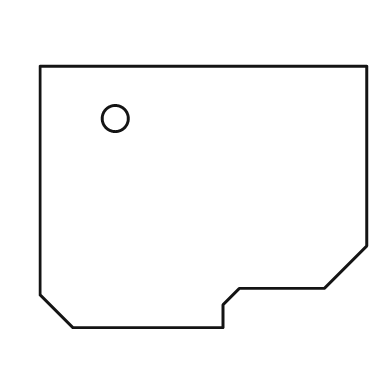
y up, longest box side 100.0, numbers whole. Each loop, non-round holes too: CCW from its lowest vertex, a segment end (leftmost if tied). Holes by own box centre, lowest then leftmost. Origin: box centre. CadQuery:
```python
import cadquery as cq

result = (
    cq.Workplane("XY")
    .moveTo(-40.0, -40.0)
    .lineTo(6.0, -40.0)
    .lineTo(6.0, -33.0)
    .lineTo(11.0, -28.0)
    .lineTo(37.0, -28.0)
    .lineTo(50.0, -15.0)
    .lineTo(50.0, 40.0)
    .lineTo(-50.0, 40.0)
    .lineTo(-50.0, -30.0)
    .close()
    .moveTo(-27.0, 24.0)
    .circle(4.0)
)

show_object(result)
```